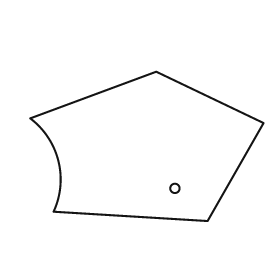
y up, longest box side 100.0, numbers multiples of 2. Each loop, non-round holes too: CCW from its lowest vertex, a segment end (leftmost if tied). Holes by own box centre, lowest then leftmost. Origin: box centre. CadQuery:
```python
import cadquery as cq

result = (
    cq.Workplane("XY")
    .moveTo(26.0, -32.0)
    .lineTo(50.0, 10.0)
    .lineTo(4.0, 32.0)
    .lineTo(-50.0, 12.0)
    .threePointArc((-38.0, -6.0), (-40.0, -28.0))
    .close()
    .moveTo(12.0, -18.0)
    .circle(2.0)
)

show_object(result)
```